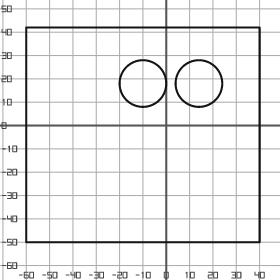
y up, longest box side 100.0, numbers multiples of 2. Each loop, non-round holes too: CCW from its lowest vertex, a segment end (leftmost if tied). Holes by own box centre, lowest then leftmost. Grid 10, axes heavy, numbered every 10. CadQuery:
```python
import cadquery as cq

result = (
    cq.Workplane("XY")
    .moveTo(-60.0, -50.0)
    .lineTo(40.0, -50.0)
    .lineTo(40.0, 42.0)
    .lineTo(-60.0, 42.0)
    .close()
    .moveTo(-10.0, 18.0)
    .circle(10.0)
    .moveTo(14.0, 18.0)
    .circle(10.0)
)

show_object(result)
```